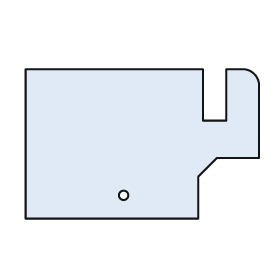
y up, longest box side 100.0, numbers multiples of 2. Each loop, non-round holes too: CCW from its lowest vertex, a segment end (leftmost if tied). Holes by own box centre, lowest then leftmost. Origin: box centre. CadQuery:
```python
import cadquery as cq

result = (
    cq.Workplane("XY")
    .moveTo(-50.0, -32.0)
    .lineTo(24.0, -32.0)
    .lineTo(24.0, -14.0)
    .lineTo(32.0, -6.0)
    .lineTo(50.0, -6.0)
    .lineTo(50.0, 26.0)
    .threePointArc((48.0, 30.0), (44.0, 32.0))
    .lineTo(36.0, 32.0)
    .lineTo(36.0, 10.0)
    .lineTo(26.0, 10.0)
    .lineTo(26.0, 32.0)
    .lineTo(-50.0, 32.0)
    .close()
    .moveTo(-8.0, -22.0)
    .circle(2.0)
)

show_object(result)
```